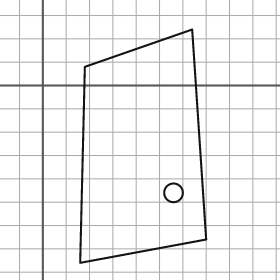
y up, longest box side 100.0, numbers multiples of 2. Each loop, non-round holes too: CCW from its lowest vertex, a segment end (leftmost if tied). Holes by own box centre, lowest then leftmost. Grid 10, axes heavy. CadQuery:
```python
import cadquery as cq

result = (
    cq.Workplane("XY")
    .moveTo(16.0, -76.0)
    .lineTo(70.0, -66.0)
    .lineTo(64.0, 24.0)
    .lineTo(18.0, 8.0)
    .close()
    .moveTo(56.0, -46.0)
    .circle(4.0)
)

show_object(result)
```